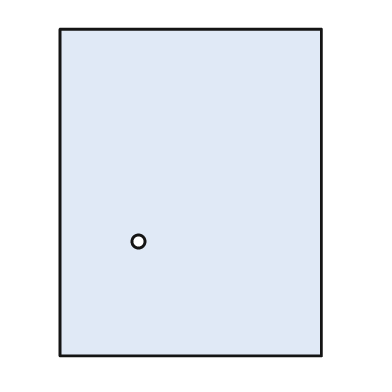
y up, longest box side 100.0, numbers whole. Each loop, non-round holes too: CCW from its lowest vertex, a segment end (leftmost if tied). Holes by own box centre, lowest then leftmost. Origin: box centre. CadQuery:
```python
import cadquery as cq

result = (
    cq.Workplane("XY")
    .moveTo(-40.0, -50.0)
    .lineTo(40.0, -50.0)
    .lineTo(40.0, 50.0)
    .lineTo(-40.0, 50.0)
    .close()
    .moveTo(-16.0, -15.0)
    .circle(2.0)
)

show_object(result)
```